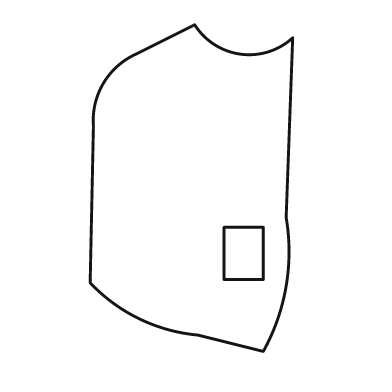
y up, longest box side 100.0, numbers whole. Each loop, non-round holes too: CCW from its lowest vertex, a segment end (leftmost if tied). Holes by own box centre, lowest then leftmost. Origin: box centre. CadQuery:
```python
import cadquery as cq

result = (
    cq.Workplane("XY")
    .moveTo(22.0, -50.0)
    .threePointArc((29.0, -30.0), (29.0, -9.0))
    .lineTo(31.0, 46.0)
    .threePointArc((15.0, 41.0), (1.0, 50.0))
    .lineTo(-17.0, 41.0)
    .threePointArc((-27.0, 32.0), (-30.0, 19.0))
    .lineTo(-31.0, -29.0)
    .threePointArc((-16.0, -40.0), (2.0, -45.0))
    .close()
    .moveTo(10.0, -28.0)
    .lineTo(22.0, -28.0)
    .lineTo(22.0, -12.0)
    .lineTo(10.0, -12.0)
    .close()
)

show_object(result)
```